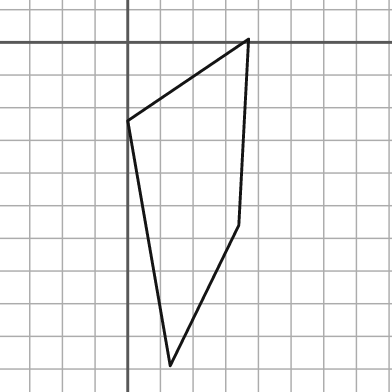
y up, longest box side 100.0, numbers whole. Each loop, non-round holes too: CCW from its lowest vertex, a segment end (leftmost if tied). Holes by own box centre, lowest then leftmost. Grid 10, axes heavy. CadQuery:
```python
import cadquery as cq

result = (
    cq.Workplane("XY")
    .moveTo(13.0, -99.0)
    .lineTo(34.0, -56.0)
    .lineTo(37.0, 1.0)
    .lineTo(0.0, -24.0)
    .close()
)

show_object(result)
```